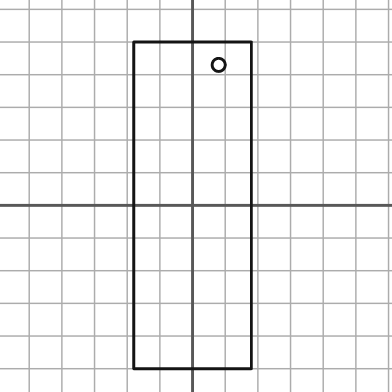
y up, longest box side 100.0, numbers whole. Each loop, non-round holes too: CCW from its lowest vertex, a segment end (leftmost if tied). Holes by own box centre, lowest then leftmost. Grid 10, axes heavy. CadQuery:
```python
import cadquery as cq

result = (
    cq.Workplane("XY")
    .moveTo(-18.0, -50.0)
    .lineTo(18.0, -50.0)
    .lineTo(18.0, 50.0)
    .lineTo(-18.0, 50.0)
    .close()
    .moveTo(8.0, 43.0)
    .circle(2.0)
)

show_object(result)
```